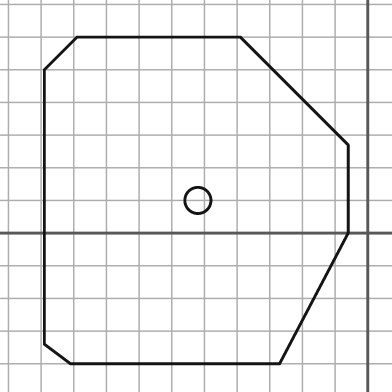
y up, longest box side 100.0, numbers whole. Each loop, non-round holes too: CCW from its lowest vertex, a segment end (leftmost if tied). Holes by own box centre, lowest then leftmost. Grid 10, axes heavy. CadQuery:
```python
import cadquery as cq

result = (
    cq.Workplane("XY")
    .moveTo(-91.0, -40.0)
    .lineTo(-27.0, -40.0)
    .lineTo(-6.0, 0.0)
    .lineTo(-6.0, 27.0)
    .lineTo(-39.0, 60.0)
    .lineTo(-89.0, 60.0)
    .lineTo(-99.0, 50.0)
    .lineTo(-99.0, -34.0)
    .close()
    .moveTo(-52.0, 10.0)
    .circle(4.0)
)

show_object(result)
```